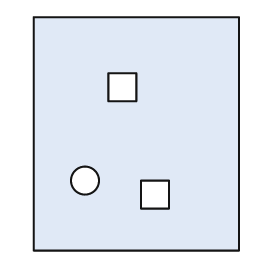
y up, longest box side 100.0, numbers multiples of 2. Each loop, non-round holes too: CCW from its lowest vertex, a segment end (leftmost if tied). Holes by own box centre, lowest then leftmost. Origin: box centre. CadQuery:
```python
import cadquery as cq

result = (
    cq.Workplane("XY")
    .moveTo(-44.0, -50.0)
    .lineTo(44.0, -50.0)
    .lineTo(44.0, 50.0)
    .lineTo(-44.0, 50.0)
    .close()
    .moveTo(2.0, -32.0)
    .lineTo(14.0, -32.0)
    .lineTo(14.0, -20.0)
    .lineTo(2.0, -20.0)
    .close()
    .moveTo(-22.0, -20.0)
    .circle(6.0)
    .moveTo(-12.0, 14.0)
    .lineTo(0.0, 14.0)
    .lineTo(0.0, 26.0)
    .lineTo(-12.0, 26.0)
    .close()
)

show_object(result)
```